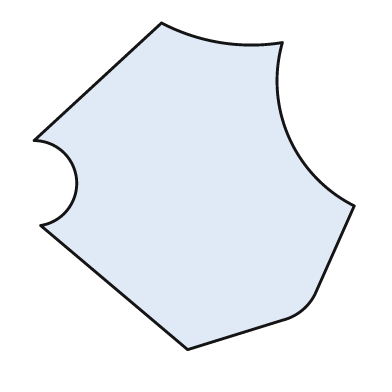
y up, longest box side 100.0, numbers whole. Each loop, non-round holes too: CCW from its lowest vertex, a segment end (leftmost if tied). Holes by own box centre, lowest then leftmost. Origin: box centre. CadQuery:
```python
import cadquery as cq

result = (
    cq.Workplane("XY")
    .moveTo(-2.0, -50.0)
    .lineTo(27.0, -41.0)
    .threePointArc((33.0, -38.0), (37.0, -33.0))
    .lineTo(49.0, -6.0)
    .threePointArc((29.0, 15.0), (27.0, 44.0))
    .threePointArc((8.0, 44.0), (-10.0, 50.0))
    .lineTo(-49.0, 14.0)
    .threePointArc((-36.0, 2.0), (-47.0, -12.0))
    .close()
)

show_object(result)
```